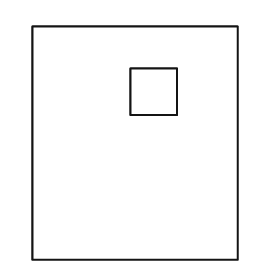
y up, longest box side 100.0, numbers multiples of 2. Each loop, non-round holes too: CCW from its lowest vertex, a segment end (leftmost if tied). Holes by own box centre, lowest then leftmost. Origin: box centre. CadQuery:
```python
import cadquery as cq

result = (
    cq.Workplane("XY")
    .moveTo(-44.0, -50.0)
    .lineTo(44.0, -50.0)
    .lineTo(44.0, 50.0)
    .lineTo(-44.0, 50.0)
    .close()
    .moveTo(-2.0, 12.0)
    .lineTo(18.0, 12.0)
    .lineTo(18.0, 32.0)
    .lineTo(-2.0, 32.0)
    .close()
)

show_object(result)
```